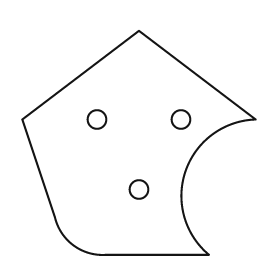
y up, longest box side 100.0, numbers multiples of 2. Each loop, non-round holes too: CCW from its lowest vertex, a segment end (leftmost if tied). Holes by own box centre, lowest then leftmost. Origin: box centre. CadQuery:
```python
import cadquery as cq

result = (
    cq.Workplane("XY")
    .moveTo(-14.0, -48.0)
    .lineTo(30.0, -48.0)
    .threePointArc((20.0, -12.0), (50.0, 10.0))
    .lineTo(0.0, 48.0)
    .lineTo(-50.0, 10.0)
    .lineTo(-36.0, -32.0)
    .threePointArc((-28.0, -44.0), (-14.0, -48.0))
    .close()
    .moveTo(0.0, -20.0)
    .circle(4.0)
    .moveTo(-18.0, 10.0)
    .circle(4.0)
    .moveTo(18.0, 10.0)
    .circle(4.0)
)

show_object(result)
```